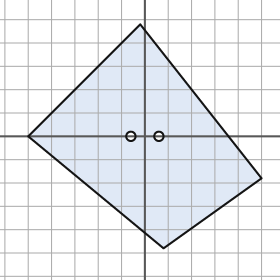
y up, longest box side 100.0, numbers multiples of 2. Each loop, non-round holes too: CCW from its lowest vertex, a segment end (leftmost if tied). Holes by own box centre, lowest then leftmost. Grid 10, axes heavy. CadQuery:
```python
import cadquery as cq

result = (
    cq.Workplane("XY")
    .moveTo(8.0, -48.0)
    .lineTo(50.0, -18.0)
    .lineTo(-2.0, 48.0)
    .lineTo(-50.0, 0.0)
    .close()
    .moveTo(-6.0, 0.0)
    .circle(2.0)
    .moveTo(6.0, 0.0)
    .circle(2.0)
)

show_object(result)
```